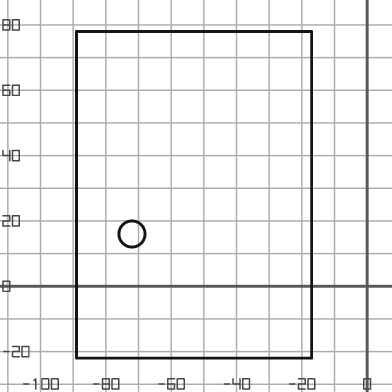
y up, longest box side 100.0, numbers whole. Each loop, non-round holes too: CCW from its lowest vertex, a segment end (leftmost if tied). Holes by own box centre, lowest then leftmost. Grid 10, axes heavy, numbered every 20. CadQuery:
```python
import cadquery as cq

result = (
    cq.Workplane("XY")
    .moveTo(-89.0, -22.0)
    .lineTo(-17.0, -22.0)
    .lineTo(-17.0, 78.0)
    .lineTo(-89.0, 78.0)
    .close()
    .moveTo(-72.0, 16.0)
    .circle(4.0)
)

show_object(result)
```